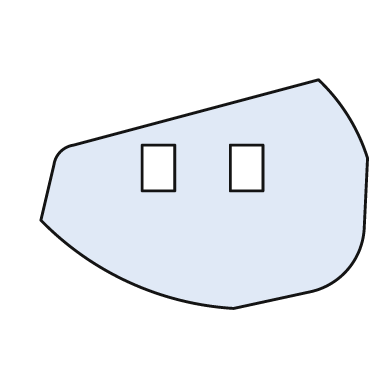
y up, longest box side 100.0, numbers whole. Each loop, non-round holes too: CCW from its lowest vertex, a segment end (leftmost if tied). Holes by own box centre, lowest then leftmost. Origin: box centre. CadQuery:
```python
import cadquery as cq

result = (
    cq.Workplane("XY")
    .moveTo(9.0, -35.0)
    .lineTo(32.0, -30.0)
    .threePointArc((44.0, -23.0), (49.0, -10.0))
    .lineTo(50.0, 11.0)
    .threePointArc((44.0, 24.0), (35.0, 35.0))
    .lineTo(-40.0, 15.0)
    .threePointArc((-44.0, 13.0), (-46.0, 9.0))
    .lineTo(-50.0, -8.0)
    .threePointArc((-23.0, -27.0), (9.0, -35.0))
    .close()
    .moveTo(-19.0, 1.0)
    .lineTo(-9.0, 1.0)
    .lineTo(-9.0, 15.0)
    .lineTo(-19.0, 15.0)
    .close()
    .moveTo(8.0, 1.0)
    .lineTo(18.0, 1.0)
    .lineTo(18.0, 15.0)
    .lineTo(8.0, 15.0)
    .close()
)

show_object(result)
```